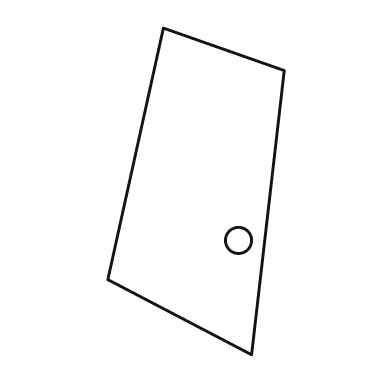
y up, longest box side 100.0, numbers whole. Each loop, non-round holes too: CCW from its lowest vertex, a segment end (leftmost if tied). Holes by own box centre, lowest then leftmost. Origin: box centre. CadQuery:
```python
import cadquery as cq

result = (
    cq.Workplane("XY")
    .moveTo(17.0, -50.0)
    .lineTo(27.0, 37.0)
    .lineTo(-10.0, 50.0)
    .lineTo(-27.0, -27.0)
    .close()
    .moveTo(13.0, -15.0)
    .circle(4.0)
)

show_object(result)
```